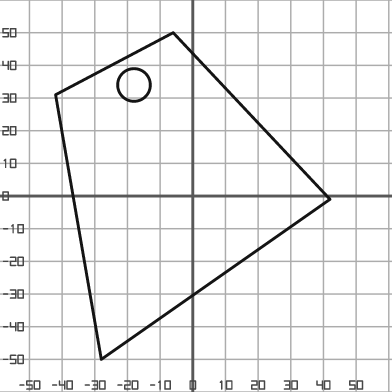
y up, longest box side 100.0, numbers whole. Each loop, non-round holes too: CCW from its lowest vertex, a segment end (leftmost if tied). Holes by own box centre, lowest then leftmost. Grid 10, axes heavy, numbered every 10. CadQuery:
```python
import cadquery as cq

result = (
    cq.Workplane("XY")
    .moveTo(-28.0, -50.0)
    .lineTo(42.0, -1.0)
    .lineTo(-6.0, 50.0)
    .lineTo(-42.0, 31.0)
    .close()
    .moveTo(-18.0, 34.0)
    .circle(5.0)
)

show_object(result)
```